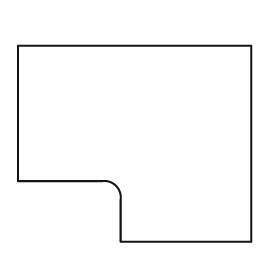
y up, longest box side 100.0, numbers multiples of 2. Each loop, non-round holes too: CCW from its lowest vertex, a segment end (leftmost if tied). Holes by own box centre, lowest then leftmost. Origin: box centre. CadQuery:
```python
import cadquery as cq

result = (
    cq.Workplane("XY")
    .moveTo(-6.0, -42.0)
    .lineTo(50.0, -42.0)
    .lineTo(50.0, 42.0)
    .lineTo(-50.0, 42.0)
    .lineTo(-50.0, -16.0)
    .lineTo(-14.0, -16.0)
    .threePointArc((-8.0, -18.0), (-6.0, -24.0))
    .close()
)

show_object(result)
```